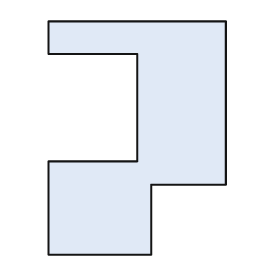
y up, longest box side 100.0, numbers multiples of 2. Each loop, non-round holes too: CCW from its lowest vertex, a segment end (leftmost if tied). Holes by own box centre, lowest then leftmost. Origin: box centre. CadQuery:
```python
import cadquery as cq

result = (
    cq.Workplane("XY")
    .moveTo(-38.0, -50.0)
    .lineTo(6.0, -50.0)
    .lineTo(6.0, -20.0)
    .lineTo(38.0, -20.0)
    .lineTo(38.0, 50.0)
    .lineTo(-38.0, 50.0)
    .lineTo(-38.0, 36.0)
    .lineTo(0.0, 36.0)
    .lineTo(0.0, -10.0)
    .lineTo(-38.0, -10.0)
    .close()
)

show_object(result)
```